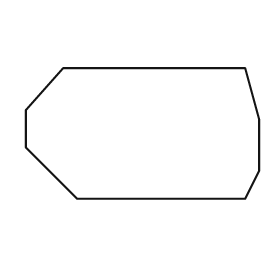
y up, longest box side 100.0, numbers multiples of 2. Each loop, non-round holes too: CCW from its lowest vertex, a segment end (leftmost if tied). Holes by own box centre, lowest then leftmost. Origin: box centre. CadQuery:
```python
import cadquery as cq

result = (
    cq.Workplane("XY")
    .moveTo(-28.0, -28.0)
    .lineTo(44.0, -28.0)
    .lineTo(50.0, -16.0)
    .lineTo(50.0, 6.0)
    .lineTo(44.0, 28.0)
    .lineTo(-34.0, 28.0)
    .lineTo(-50.0, 10.0)
    .lineTo(-50.0, -6.0)
    .close()
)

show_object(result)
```